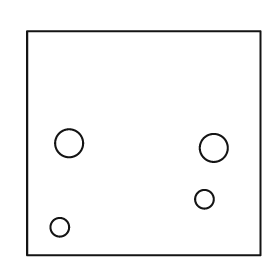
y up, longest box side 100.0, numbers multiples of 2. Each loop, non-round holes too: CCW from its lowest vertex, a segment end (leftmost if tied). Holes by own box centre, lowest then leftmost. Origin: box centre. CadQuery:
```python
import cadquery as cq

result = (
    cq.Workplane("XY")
    .moveTo(-50.0, -48.0)
    .lineTo(50.0, -48.0)
    .lineTo(50.0, 48.0)
    .lineTo(-50.0, 48.0)
    .close()
    .moveTo(-36.0, -36.0)
    .circle(4.0)
    .moveTo(26.0, -24.0)
    .circle(4.0)
    .moveTo(30.0, -2.0)
    .circle(6.0)
    .moveTo(-32.0, 0.0)
    .circle(6.0)
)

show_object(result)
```